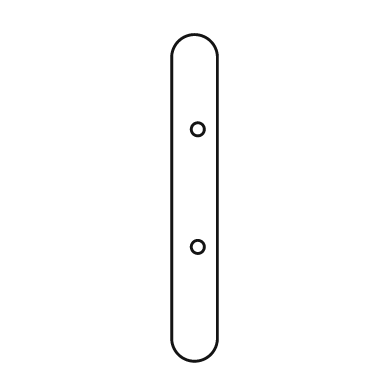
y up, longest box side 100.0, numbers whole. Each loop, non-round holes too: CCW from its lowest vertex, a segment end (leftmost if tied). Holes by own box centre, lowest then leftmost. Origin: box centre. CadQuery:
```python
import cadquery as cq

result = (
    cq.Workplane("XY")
    .moveTo(-7.0, -43.0)
    .threePointArc((0.0, -50.0), (7.0, -43.0))
    .lineTo(7.0, 43.0)
    .threePointArc((0.0, 50.0), (-7.0, 43.0))
    .close()
    .moveTo(1.0, -15.0)
    .circle(2.0)
    .moveTo(1.0, 21.0)
    .circle(2.0)
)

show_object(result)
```